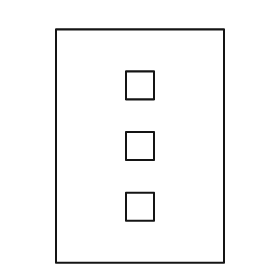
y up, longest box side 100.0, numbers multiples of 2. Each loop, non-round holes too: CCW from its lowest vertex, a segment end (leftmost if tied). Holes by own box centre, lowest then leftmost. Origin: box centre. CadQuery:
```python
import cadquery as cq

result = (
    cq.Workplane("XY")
    .moveTo(-36.0, -50.0)
    .lineTo(36.0, -50.0)
    .lineTo(36.0, 50.0)
    .lineTo(-36.0, 50.0)
    .close()
    .moveTo(-6.0, -32.0)
    .lineTo(6.0, -32.0)
    .lineTo(6.0, -20.0)
    .lineTo(-6.0, -20.0)
    .close()
    .moveTo(-6.0, -6.0)
    .lineTo(6.0, -6.0)
    .lineTo(6.0, 6.0)
    .lineTo(-6.0, 6.0)
    .close()
    .moveTo(-6.0, 20.0)
    .lineTo(6.0, 20.0)
    .lineTo(6.0, 32.0)
    .lineTo(-6.0, 32.0)
    .close()
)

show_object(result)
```